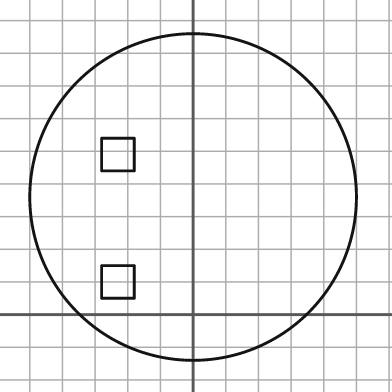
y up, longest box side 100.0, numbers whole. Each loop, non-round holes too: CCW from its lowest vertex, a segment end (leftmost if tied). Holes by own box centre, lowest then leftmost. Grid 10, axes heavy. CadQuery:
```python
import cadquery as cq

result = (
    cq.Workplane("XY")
    .moveTo(0.0, 36.0)
    .circle(50.0)
    .moveTo(-28.0, 5.0)
    .lineTo(-18.0, 5.0)
    .lineTo(-18.0, 15.0)
    .lineTo(-28.0, 15.0)
    .close()
    .moveTo(-28.0, 44.0)
    .lineTo(-18.0, 44.0)
    .lineTo(-18.0, 54.0)
    .lineTo(-28.0, 54.0)
    .close()
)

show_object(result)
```